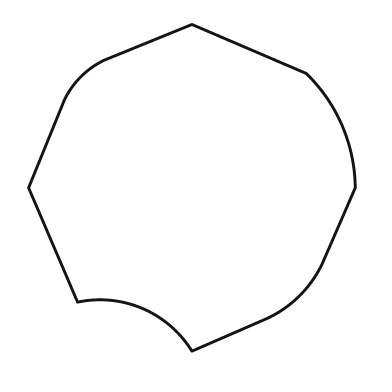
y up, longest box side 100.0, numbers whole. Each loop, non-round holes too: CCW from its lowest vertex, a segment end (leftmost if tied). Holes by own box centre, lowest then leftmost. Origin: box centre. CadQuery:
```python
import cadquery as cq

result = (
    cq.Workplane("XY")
    .moveTo(0.0, -50.0)
    .lineTo(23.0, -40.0)
    .threePointArc((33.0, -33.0), (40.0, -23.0))
    .lineTo(50.0, 0.0)
    .threePointArc((46.0, 19.0), (35.0, 35.0))
    .lineTo(0.0, 50.0)
    .lineTo(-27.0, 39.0)
    .threePointArc((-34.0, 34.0), (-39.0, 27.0))
    .lineTo(-50.0, 0.0)
    .lineTo(-35.0, -35.0)
    .threePointArc((-15.0, -37.0), (0.0, -50.0))
    .close()
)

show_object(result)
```